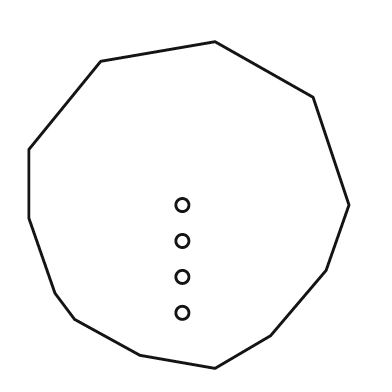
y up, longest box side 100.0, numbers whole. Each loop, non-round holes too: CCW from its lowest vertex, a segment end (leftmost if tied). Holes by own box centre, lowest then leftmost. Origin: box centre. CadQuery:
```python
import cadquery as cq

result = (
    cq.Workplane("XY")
    .moveTo(8.0, -50.0)
    .lineTo(25.0, -40.0)
    .lineTo(42.0, -20.0)
    .lineTo(49.0, 0.0)
    .lineTo(38.0, 33.0)
    .lineTo(8.0, 50.0)
    .lineTo(-27.0, 44.0)
    .lineTo(-49.0, 17.0)
    .lineTo(-49.0, -4.0)
    .lineTo(-41.0, -27.0)
    .lineTo(-35.0, -35.0)
    .lineTo(-15.0, -46.0)
    .close()
    .moveTo(-2.0, -33.0)
    .circle(2.0)
    .moveTo(-2.0, -22.0)
    .circle(2.0)
    .moveTo(-2.0, -11.0)
    .circle(2.0)
    .moveTo(-2.0, 0.0)
    .circle(2.0)
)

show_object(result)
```